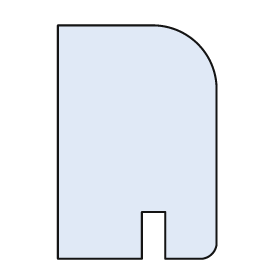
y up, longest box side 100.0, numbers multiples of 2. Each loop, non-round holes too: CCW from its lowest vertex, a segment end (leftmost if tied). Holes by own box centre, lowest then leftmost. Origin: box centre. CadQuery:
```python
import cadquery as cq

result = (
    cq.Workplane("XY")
    .moveTo(-34.0, -50.0)
    .lineTo(2.0, -50.0)
    .lineTo(2.0, -30.0)
    .lineTo(12.0, -30.0)
    .lineTo(12.0, -50.0)
    .lineTo(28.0, -50.0)
    .threePointArc((32.0, -48.0), (34.0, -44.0))
    .lineTo(34.0, 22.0)
    .threePointArc((26.0, 42.0), (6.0, 50.0))
    .lineTo(-34.0, 50.0)
    .close()
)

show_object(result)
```